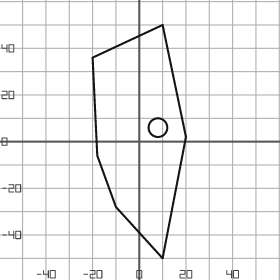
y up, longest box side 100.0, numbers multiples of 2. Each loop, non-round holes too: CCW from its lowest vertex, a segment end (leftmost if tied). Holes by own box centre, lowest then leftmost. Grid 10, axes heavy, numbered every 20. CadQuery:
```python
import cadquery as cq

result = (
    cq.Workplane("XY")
    .moveTo(10.0, -50.0)
    .lineTo(20.0, 2.0)
    .lineTo(10.0, 50.0)
    .lineTo(-20.0, 36.0)
    .lineTo(-18.0, -6.0)
    .lineTo(-10.0, -28.0)
    .close()
    .moveTo(8.0, 6.0)
    .circle(4.0)
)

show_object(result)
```